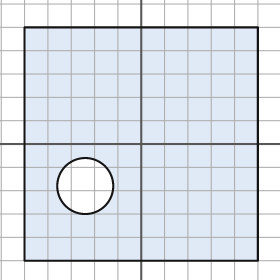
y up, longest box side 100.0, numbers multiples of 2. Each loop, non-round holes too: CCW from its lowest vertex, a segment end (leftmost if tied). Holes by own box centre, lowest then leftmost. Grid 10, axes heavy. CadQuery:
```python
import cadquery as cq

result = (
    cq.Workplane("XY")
    .moveTo(-50.0, -50.0)
    .lineTo(50.0, -50.0)
    .lineTo(50.0, 50.0)
    .lineTo(-50.0, 50.0)
    .close()
    .moveTo(-24.0, -18.0)
    .circle(12.0)
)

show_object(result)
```